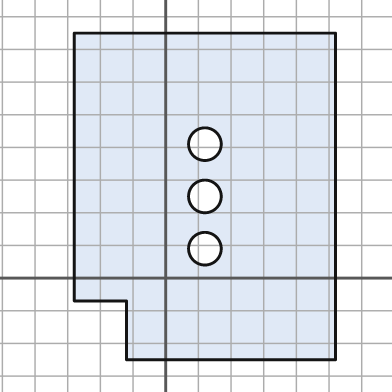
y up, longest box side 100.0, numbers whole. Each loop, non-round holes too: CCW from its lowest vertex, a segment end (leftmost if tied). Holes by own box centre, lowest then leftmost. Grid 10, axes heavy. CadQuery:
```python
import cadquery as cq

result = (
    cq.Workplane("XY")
    .moveTo(-12.0, -25.0)
    .lineTo(52.0, -25.0)
    .lineTo(52.0, 75.0)
    .lineTo(-28.0, 75.0)
    .lineTo(-28.0, -7.0)
    .lineTo(-12.0, -7.0)
    .close()
    .moveTo(12.0, 9.0)
    .circle(5.0)
    .moveTo(12.0, 25.0)
    .circle(5.0)
    .moveTo(12.0, 41.0)
    .circle(5.0)
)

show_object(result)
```